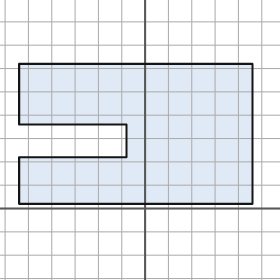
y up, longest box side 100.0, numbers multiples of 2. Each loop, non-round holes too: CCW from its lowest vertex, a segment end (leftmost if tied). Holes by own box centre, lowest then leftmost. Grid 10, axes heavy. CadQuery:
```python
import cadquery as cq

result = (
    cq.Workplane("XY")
    .moveTo(-54.0, 2.0)
    .lineTo(46.0, 2.0)
    .lineTo(46.0, 62.0)
    .lineTo(-54.0, 62.0)
    .lineTo(-54.0, 36.0)
    .lineTo(-8.0, 36.0)
    .lineTo(-8.0, 22.0)
    .lineTo(-54.0, 22.0)
    .close()
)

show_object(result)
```